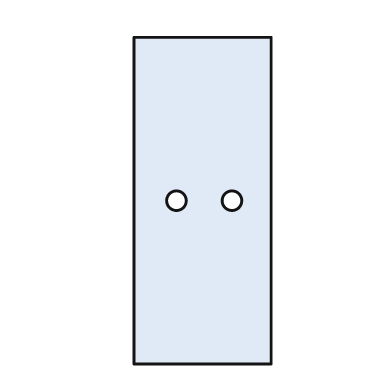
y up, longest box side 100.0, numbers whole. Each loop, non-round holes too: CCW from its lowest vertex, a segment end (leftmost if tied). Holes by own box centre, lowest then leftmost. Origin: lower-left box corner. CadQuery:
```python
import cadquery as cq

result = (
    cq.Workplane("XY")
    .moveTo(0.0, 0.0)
    .lineTo(42.0, 0.0)
    .lineTo(42.0, 100.0)
    .lineTo(0.0, 100.0)
    .close()
    .moveTo(13.0, 50.0)
    .circle(3.0)
    .moveTo(30.0, 50.0)
    .circle(3.0)
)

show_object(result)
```